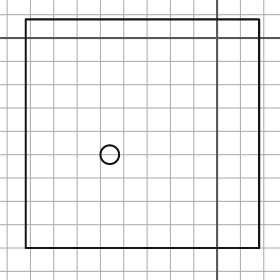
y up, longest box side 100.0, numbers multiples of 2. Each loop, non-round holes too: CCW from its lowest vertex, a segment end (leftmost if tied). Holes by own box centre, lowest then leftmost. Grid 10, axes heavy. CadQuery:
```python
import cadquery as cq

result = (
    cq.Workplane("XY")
    .moveTo(-82.0, -90.0)
    .lineTo(18.0, -90.0)
    .lineTo(18.0, 8.0)
    .lineTo(-82.0, 8.0)
    .close()
    .moveTo(-46.0, -50.0)
    .circle(4.0)
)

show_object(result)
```